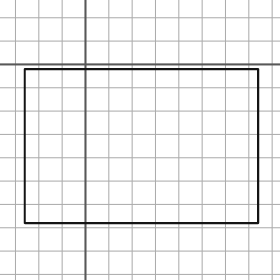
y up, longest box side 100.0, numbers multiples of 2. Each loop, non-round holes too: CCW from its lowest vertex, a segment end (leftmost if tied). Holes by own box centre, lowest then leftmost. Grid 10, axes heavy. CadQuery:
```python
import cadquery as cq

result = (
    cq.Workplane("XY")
    .moveTo(-26.0, -68.0)
    .lineTo(74.0, -68.0)
    .lineTo(74.0, -2.0)
    .lineTo(-26.0, -2.0)
    .close()
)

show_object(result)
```